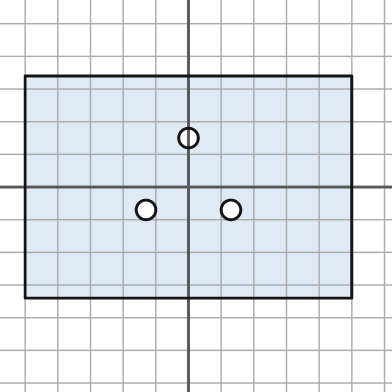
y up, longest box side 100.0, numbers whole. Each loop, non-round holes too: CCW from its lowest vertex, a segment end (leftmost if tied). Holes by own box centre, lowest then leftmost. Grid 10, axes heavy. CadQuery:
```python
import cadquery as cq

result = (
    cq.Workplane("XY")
    .moveTo(-50.0, -34.0)
    .lineTo(50.0, -34.0)
    .lineTo(50.0, 34.0)
    .lineTo(-50.0, 34.0)
    .close()
    .moveTo(-13.0, -7.0)
    .circle(3.0)
    .moveTo(13.0, -7.0)
    .circle(3.0)
    .moveTo(0.0, 15.0)
    .circle(3.0)
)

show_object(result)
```